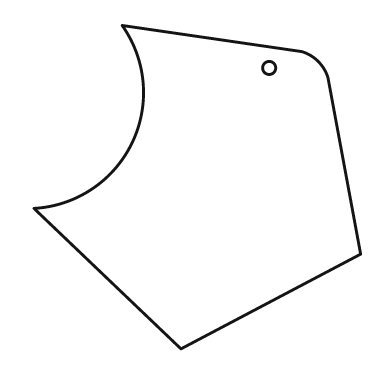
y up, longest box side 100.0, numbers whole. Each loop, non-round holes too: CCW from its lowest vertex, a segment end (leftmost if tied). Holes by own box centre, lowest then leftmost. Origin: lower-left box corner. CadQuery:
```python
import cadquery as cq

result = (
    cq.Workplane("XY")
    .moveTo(45.0, 0.0)
    .lineTo(100.0, 29.0)
    .lineTo(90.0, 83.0)
    .threePointArc((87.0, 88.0), (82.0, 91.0))
    .lineTo(27.0, 99.0)
    .threePointArc((30.0, 63.0), (0.0, 43.0))
    .close()
    .moveTo(72.0, 86.0)
    .circle(2.0)
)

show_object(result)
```